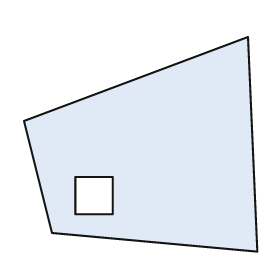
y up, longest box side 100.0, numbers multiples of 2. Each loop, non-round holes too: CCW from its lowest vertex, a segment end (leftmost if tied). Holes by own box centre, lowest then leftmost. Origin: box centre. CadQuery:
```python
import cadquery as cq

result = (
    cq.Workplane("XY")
    .moveTo(50.0, -46.0)
    .lineTo(46.0, 46.0)
    .lineTo(-50.0, 10.0)
    .lineTo(-38.0, -38.0)
    .close()
    .moveTo(-28.0, -30.0)
    .lineTo(-12.0, -30.0)
    .lineTo(-12.0, -14.0)
    .lineTo(-28.0, -14.0)
    .close()
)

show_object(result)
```